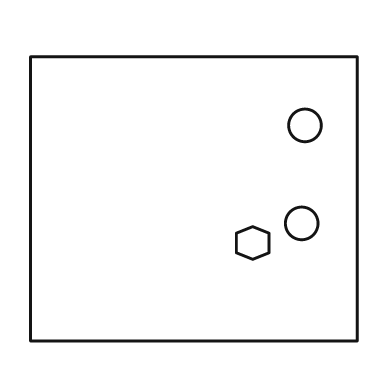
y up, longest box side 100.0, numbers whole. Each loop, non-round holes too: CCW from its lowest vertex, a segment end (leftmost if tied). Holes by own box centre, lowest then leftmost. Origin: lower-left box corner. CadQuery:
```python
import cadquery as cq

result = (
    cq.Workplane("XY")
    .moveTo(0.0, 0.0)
    .lineTo(100.0, 0.0)
    .lineTo(100.0, 87.0)
    .lineTo(0.0, 87.0)
    .close()
    .moveTo(68.0, 25.0)
    .lineTo(73.0, 27.0)
    .lineTo(73.0, 33.0)
    .lineTo(68.0, 35.0)
    .lineTo(63.0, 33.0)
    .lineTo(63.0, 27.0)
    .close()
    .moveTo(83.0, 36.0)
    .circle(5.0)
    .moveTo(84.0, 66.0)
    .circle(5.0)
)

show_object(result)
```